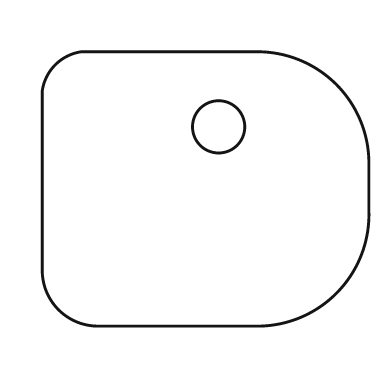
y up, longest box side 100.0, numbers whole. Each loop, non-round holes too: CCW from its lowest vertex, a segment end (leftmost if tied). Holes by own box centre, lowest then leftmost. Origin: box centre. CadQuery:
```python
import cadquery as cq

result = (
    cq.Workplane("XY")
    .moveTo(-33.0, -42.0)
    .lineTo(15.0, -42.0)
    .threePointArc((40.0, -32.0), (50.0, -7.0))
    .lineTo(50.0, 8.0)
    .threePointArc((40.0, 32.0), (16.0, 42.0))
    .lineTo(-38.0, 42.0)
    .threePointArc((-46.0, 38.0), (-50.0, 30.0))
    .lineTo(-50.0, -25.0)
    .threePointArc((-45.0, -37.0), (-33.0, -42.0))
    .close()
    .moveTo(4.0, 19.0)
    .circle(8.0)
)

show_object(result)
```